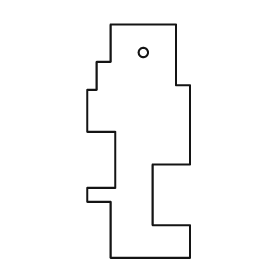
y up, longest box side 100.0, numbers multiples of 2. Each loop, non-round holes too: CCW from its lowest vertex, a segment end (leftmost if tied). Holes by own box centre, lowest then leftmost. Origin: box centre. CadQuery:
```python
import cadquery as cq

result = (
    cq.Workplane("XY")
    .moveTo(-12.0, -50.0)
    .lineTo(22.0, -50.0)
    .lineTo(22.0, -36.0)
    .lineTo(6.0, -36.0)
    .lineTo(6.0, -10.0)
    .lineTo(22.0, -10.0)
    .lineTo(22.0, 24.0)
    .lineTo(16.0, 24.0)
    .lineTo(16.0, 50.0)
    .lineTo(-12.0, 50.0)
    .lineTo(-12.0, 34.0)
    .lineTo(-18.0, 34.0)
    .lineTo(-18.0, 22.0)
    .lineTo(-22.0, 22.0)
    .lineTo(-22.0, 4.0)
    .lineTo(-10.0, 4.0)
    .lineTo(-10.0, -20.0)
    .lineTo(-22.0, -20.0)
    .lineTo(-22.0, -26.0)
    .lineTo(-12.0, -26.0)
    .close()
    .moveTo(2.0, 38.0)
    .circle(2.0)
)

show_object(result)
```